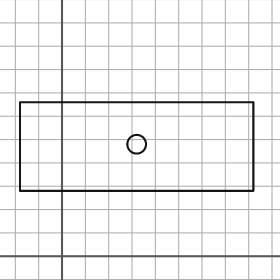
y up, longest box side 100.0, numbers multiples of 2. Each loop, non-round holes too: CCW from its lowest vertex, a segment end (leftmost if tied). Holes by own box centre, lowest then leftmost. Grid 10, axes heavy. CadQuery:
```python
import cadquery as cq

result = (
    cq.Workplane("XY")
    .moveTo(-18.0, 28.0)
    .lineTo(82.0, 28.0)
    .lineTo(82.0, 66.0)
    .lineTo(-18.0, 66.0)
    .close()
    .moveTo(32.0, 48.0)
    .circle(4.0)
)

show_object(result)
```